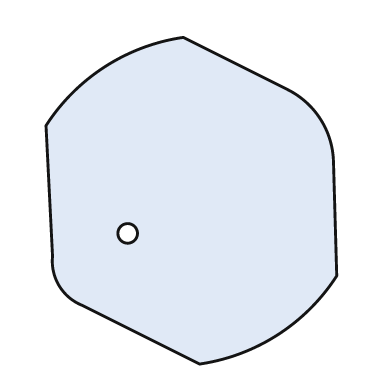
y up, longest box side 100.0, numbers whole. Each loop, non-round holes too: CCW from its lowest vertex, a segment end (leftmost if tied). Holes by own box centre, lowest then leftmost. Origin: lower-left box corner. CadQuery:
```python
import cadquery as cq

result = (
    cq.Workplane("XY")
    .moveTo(47.0, 0.0)
    .threePointArc((71.0, 9.0), (89.0, 27.0))
    .lineTo(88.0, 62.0)
    .threePointArc((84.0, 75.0), (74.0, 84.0))
    .lineTo(42.0, 100.0)
    .threePointArc((18.0, 91.0), (0.0, 73.0))
    .lineTo(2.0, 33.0)
    .threePointArc((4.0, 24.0), (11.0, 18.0))
    .close()
    .moveTo(25.0, 40.0)
    .circle(3.0)
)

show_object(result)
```